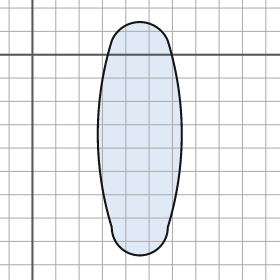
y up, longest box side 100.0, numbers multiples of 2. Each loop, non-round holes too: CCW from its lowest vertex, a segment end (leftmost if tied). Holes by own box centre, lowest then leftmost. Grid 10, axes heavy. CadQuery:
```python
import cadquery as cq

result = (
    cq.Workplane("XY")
    .moveTo(34.0, -74.0)
    .threePointArc((46.0, -86.0), (58.0, -74.0))
    .threePointArc((64.0, -34.0), (58.0, 6.0))
    .threePointArc((46.0, 14.0), (34.0, 6.0))
    .threePointArc((28.0, -34.0), (34.0, -74.0))
    .close()
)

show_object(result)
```